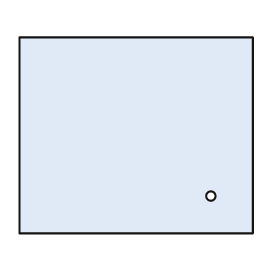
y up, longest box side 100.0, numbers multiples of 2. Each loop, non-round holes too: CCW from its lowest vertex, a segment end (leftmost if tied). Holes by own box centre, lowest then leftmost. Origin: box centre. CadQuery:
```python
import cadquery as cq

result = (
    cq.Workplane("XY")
    .moveTo(-50.0, -42.0)
    .lineTo(50.0, -42.0)
    .lineTo(50.0, 42.0)
    .lineTo(-50.0, 42.0)
    .close()
    .moveTo(32.0, -26.0)
    .circle(2.0)
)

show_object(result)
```